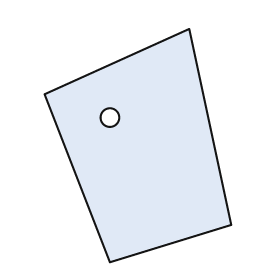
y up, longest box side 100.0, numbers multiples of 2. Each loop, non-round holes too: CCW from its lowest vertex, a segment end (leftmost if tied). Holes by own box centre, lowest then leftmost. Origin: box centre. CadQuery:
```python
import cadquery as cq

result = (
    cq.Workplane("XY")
    .moveTo(-12.0, -50.0)
    .lineTo(40.0, -34.0)
    .lineTo(22.0, 50.0)
    .lineTo(-40.0, 22.0)
    .close()
    .moveTo(-12.0, 12.0)
    .circle(4.0)
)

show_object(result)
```